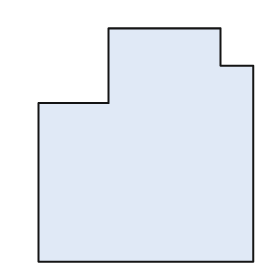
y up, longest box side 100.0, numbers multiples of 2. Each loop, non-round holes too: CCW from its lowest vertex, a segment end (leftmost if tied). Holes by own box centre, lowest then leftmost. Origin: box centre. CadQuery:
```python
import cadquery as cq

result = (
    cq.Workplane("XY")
    .moveTo(-46.0, -50.0)
    .lineTo(46.0, -50.0)
    .lineTo(46.0, 34.0)
    .lineTo(32.0, 34.0)
    .lineTo(32.0, 50.0)
    .lineTo(-16.0, 50.0)
    .lineTo(-16.0, 18.0)
    .lineTo(-46.0, 18.0)
    .close()
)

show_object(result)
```